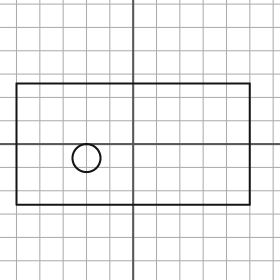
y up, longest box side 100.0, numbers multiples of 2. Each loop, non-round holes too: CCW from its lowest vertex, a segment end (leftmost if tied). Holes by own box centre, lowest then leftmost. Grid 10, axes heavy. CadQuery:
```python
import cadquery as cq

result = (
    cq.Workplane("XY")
    .moveTo(-50.0, -26.0)
    .lineTo(50.0, -26.0)
    .lineTo(50.0, 26.0)
    .lineTo(-50.0, 26.0)
    .close()
    .moveTo(-20.0, -6.0)
    .circle(6.0)
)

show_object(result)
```